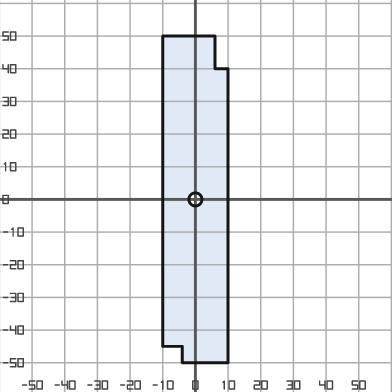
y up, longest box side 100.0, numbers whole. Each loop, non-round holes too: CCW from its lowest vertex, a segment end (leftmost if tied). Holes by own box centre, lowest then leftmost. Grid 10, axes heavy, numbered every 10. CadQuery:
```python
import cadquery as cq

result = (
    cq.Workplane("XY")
    .moveTo(-4.0, -50.0)
    .lineTo(10.0, -50.0)
    .lineTo(10.0, 40.0)
    .lineTo(6.0, 40.0)
    .lineTo(6.0, 50.0)
    .lineTo(-10.0, 50.0)
    .lineTo(-10.0, -45.0)
    .lineTo(-4.0, -45.0)
    .close()
    .moveTo(0.0, 0.0)
    .circle(2.0)
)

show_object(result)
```